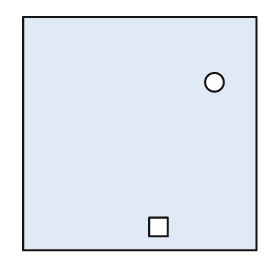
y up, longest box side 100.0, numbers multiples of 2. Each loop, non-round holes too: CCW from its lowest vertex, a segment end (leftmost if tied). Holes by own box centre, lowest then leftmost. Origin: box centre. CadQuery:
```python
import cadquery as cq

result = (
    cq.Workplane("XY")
    .moveTo(-50.0, -50.0)
    .lineTo(50.0, -50.0)
    .lineTo(50.0, 50.0)
    .lineTo(-50.0, 50.0)
    .close()
    .moveTo(4.0, -44.0)
    .lineTo(12.0, -44.0)
    .lineTo(12.0, -36.0)
    .lineTo(4.0, -36.0)
    .close()
    .moveTo(32.0, 22.0)
    .circle(4.0)
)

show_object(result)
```